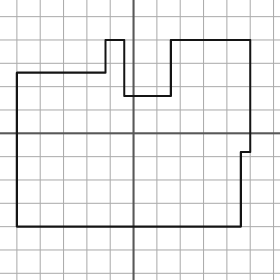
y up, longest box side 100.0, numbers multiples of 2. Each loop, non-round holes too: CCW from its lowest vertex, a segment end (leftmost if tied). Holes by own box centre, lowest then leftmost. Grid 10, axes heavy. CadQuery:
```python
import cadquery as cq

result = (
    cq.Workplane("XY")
    .moveTo(-50.0, -40.0)
    .lineTo(46.0, -40.0)
    .lineTo(46.0, -8.0)
    .lineTo(50.0, -8.0)
    .lineTo(50.0, 40.0)
    .lineTo(16.0, 40.0)
    .lineTo(16.0, 16.0)
    .lineTo(-4.0, 16.0)
    .lineTo(-4.0, 40.0)
    .lineTo(-12.0, 40.0)
    .lineTo(-12.0, 26.0)
    .lineTo(-50.0, 26.0)
    .close()
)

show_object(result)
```